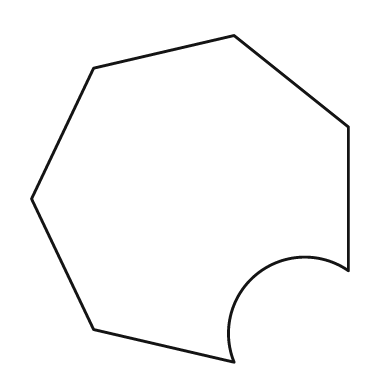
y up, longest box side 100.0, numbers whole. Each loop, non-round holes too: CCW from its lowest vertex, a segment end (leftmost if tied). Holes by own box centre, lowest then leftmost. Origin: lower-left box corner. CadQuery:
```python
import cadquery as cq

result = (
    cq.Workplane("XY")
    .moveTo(62.0, 0.0)
    .threePointArc((69.0, 27.0), (97.0, 28.0))
    .lineTo(97.0, 72.0)
    .lineTo(62.0, 100.0)
    .lineTo(19.0, 90.0)
    .lineTo(0.0, 50.0)
    .lineTo(19.0, 10.0)
    .close()
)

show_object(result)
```